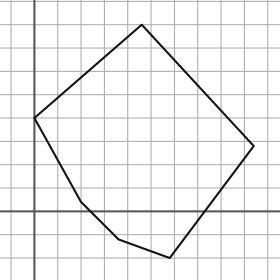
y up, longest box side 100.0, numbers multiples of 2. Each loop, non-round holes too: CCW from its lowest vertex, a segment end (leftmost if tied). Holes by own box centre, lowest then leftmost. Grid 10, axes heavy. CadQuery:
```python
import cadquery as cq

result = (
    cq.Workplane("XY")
    .moveTo(58.0, -20.0)
    .lineTo(94.0, 28.0)
    .lineTo(46.0, 80.0)
    .lineTo(0.0, 40.0)
    .lineTo(20.0, 4.0)
    .lineTo(36.0, -12.0)
    .close()
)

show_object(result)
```